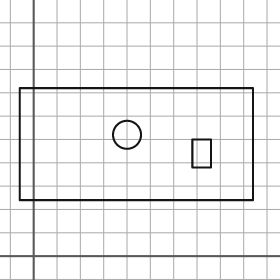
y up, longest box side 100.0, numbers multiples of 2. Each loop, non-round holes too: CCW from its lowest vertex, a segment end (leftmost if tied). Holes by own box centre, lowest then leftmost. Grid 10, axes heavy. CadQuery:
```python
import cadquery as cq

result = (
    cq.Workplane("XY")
    .moveTo(-6.0, 24.0)
    .lineTo(94.0, 24.0)
    .lineTo(94.0, 72.0)
    .lineTo(-6.0, 72.0)
    .close()
    .moveTo(68.0, 38.0)
    .lineTo(76.0, 38.0)
    .lineTo(76.0, 50.0)
    .lineTo(68.0, 50.0)
    .close()
    .moveTo(40.0, 52.0)
    .circle(6.0)
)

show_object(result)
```